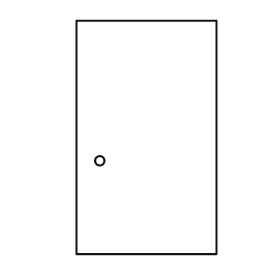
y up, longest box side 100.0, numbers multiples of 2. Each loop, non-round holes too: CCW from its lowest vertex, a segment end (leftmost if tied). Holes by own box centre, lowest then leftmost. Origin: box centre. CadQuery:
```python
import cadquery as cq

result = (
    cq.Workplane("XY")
    .moveTo(-30.0, -50.0)
    .lineTo(30.0, -50.0)
    .lineTo(30.0, 50.0)
    .lineTo(-30.0, 50.0)
    .close()
    .moveTo(-20.0, -10.0)
    .circle(2.0)
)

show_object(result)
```